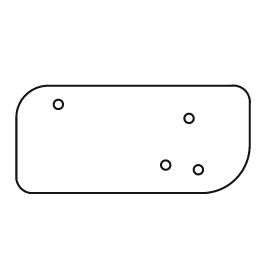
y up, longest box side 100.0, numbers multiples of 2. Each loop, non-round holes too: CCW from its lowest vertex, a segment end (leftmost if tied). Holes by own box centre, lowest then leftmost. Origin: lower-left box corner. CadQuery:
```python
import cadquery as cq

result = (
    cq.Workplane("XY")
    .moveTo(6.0, 0.0)
    .lineTo(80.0, 0.0)
    .threePointArc((94.0, 6.0), (100.0, 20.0))
    .lineTo(100.0, 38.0)
    .threePointArc((98.0, 44.0), (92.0, 46.0))
    .lineTo(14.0, 46.0)
    .threePointArc((4.0, 42.0), (0.0, 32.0))
    .lineTo(0.0, 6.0)
    .threePointArc((2.0, 2.0), (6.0, 0.0))
    .close()
    .moveTo(78.0, 10.0)
    .circle(2.0)
    .moveTo(64.0, 12.0)
    .circle(2.0)
    .moveTo(74.0, 32.0)
    .circle(2.0)
    .moveTo(18.0, 38.0)
    .circle(2.0)
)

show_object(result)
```